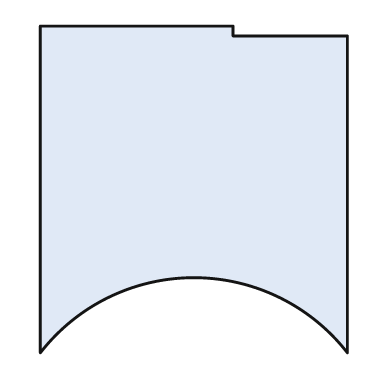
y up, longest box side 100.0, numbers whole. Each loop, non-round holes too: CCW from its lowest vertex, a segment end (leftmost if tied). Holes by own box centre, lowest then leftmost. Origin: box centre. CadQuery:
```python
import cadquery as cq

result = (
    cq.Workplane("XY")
    .moveTo(-47.0, -50.0)
    .threePointArc((0.0, -27.0), (47.0, -50.0))
    .lineTo(47.0, 47.0)
    .lineTo(12.0, 47.0)
    .lineTo(12.0, 50.0)
    .lineTo(-47.0, 50.0)
    .close()
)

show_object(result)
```